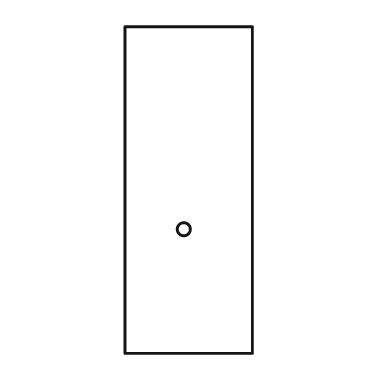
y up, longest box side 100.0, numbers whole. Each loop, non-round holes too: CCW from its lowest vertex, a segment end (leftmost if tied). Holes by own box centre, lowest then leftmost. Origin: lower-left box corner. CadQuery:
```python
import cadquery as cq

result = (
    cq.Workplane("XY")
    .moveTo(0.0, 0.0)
    .lineTo(39.0, 0.0)
    .lineTo(39.0, 100.0)
    .lineTo(0.0, 100.0)
    .close()
    .moveTo(18.0, 38.0)
    .circle(2.0)
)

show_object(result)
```